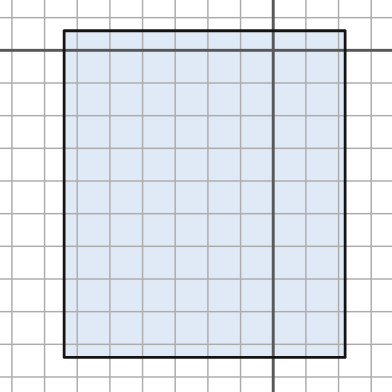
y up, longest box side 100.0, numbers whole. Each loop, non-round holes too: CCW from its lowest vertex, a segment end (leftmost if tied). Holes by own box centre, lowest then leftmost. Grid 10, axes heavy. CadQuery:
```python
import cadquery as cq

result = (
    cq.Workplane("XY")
    .moveTo(-64.0, -94.0)
    .lineTo(22.0, -94.0)
    .lineTo(22.0, 6.0)
    .lineTo(-64.0, 6.0)
    .close()
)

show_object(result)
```